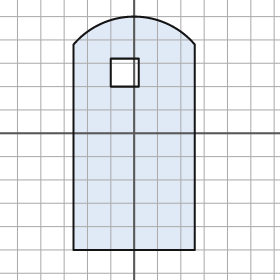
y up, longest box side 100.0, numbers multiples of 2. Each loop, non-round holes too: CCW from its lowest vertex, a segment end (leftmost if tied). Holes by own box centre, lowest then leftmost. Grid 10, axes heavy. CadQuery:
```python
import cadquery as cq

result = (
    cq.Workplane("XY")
    .moveTo(-26.0, -50.0)
    .lineTo(26.0, -50.0)
    .lineTo(26.0, 38.0)
    .threePointArc((0.0, 50.0), (-26.0, 38.0))
    .close()
    .moveTo(-10.0, 20.0)
    .lineTo(2.0, 20.0)
    .lineTo(2.0, 32.0)
    .lineTo(-10.0, 32.0)
    .close()
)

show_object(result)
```